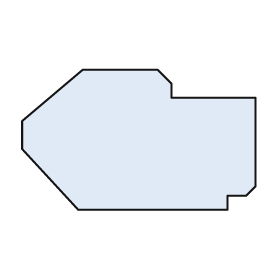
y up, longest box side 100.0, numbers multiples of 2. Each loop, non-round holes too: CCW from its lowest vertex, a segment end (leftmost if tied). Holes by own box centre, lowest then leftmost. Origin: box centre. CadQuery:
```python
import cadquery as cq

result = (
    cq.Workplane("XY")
    .moveTo(-26.0, -30.0)
    .lineTo(38.0, -30.0)
    .lineTo(38.0, -24.0)
    .lineTo(46.0, -24.0)
    .lineTo(50.0, -20.0)
    .lineTo(50.0, 18.0)
    .lineTo(14.0, 18.0)
    .lineTo(14.0, 24.0)
    .lineTo(8.0, 30.0)
    .lineTo(-24.0, 30.0)
    .lineTo(-50.0, 8.0)
    .lineTo(-50.0, -4.0)
    .close()
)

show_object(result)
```